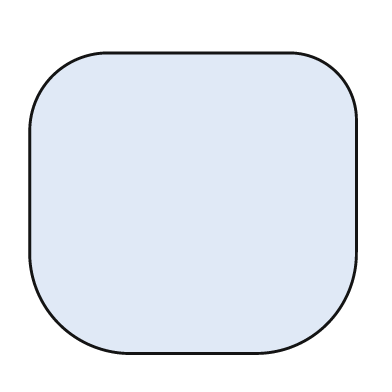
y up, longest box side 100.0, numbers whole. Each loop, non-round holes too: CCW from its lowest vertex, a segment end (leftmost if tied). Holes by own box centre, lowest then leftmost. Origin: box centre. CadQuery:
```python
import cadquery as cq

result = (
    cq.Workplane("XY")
    .moveTo(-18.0, -46.0)
    .lineTo(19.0, -46.0)
    .threePointArc((41.0, -37.0), (50.0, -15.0))
    .lineTo(50.0, 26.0)
    .threePointArc((44.0, 40.0), (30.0, 46.0))
    .lineTo(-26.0, 46.0)
    .threePointArc((-43.0, 39.0), (-50.0, 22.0))
    .lineTo(-50.0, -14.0)
    .threePointArc((-41.0, -37.0), (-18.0, -46.0))
    .close()
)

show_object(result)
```